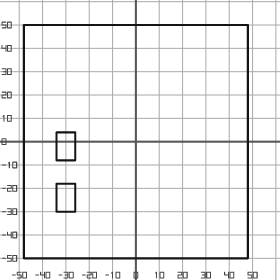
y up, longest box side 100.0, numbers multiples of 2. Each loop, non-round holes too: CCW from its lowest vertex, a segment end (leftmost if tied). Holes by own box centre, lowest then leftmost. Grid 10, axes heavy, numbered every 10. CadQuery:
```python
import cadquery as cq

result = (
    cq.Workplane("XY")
    .moveTo(-48.0, -50.0)
    .lineTo(48.0, -50.0)
    .lineTo(48.0, 50.0)
    .lineTo(-48.0, 50.0)
    .close()
    .moveTo(-34.0, -30.0)
    .lineTo(-26.0, -30.0)
    .lineTo(-26.0, -18.0)
    .lineTo(-34.0, -18.0)
    .close()
    .moveTo(-34.0, -8.0)
    .lineTo(-26.0, -8.0)
    .lineTo(-26.0, 4.0)
    .lineTo(-34.0, 4.0)
    .close()
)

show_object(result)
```